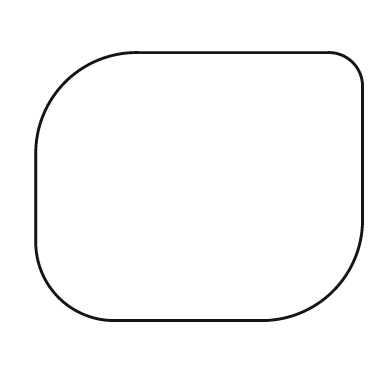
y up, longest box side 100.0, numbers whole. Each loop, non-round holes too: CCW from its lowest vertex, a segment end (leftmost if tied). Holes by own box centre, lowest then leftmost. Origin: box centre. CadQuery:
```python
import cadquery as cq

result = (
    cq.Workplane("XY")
    .moveTo(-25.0, -41.0)
    .lineTo(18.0, -41.0)
    .threePointArc((41.0, -32.0), (50.0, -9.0))
    .lineTo(50.0, 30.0)
    .threePointArc((47.0, 38.0), (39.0, 41.0))
    .lineTo(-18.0, 41.0)
    .threePointArc((-41.0, 32.0), (-50.0, 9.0))
    .lineTo(-50.0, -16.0)
    .threePointArc((-43.0, -34.0), (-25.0, -41.0))
    .close()
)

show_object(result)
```